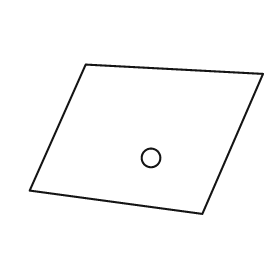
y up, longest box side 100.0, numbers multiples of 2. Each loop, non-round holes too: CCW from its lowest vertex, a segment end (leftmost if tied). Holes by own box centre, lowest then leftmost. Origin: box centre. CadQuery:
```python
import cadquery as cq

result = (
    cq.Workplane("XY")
    .moveTo(24.0, -32.0)
    .lineTo(50.0, 28.0)
    .lineTo(-26.0, 32.0)
    .lineTo(-50.0, -22.0)
    .close()
    .moveTo(2.0, -8.0)
    .circle(4.0)
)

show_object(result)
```